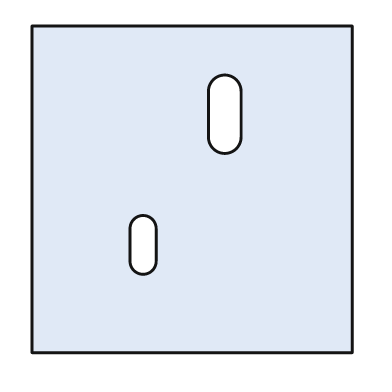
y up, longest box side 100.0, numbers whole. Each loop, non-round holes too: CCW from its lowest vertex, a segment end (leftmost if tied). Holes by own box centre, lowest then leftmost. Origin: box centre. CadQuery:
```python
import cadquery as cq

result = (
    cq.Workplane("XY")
    .moveTo(-49.0, -50.0)
    .lineTo(49.0, -50.0)
    .lineTo(49.0, 50.0)
    .lineTo(-49.0, 50.0)
    .close()
    .moveTo(-19.0, -22.0)
    .threePointArc((-15.0, -26.0), (-11.0, -22.0))
    .lineTo(-11.0, -12.0)
    .threePointArc((-15.0, -8.0), (-19.0, -12.0))
    .close()
    .moveTo(5.0, 16.0)
    .threePointArc((10.0, 11.0), (15.0, 16.0))
    .lineTo(15.0, 30.0)
    .threePointArc((10.0, 35.0), (5.0, 30.0))
    .close()
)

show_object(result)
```